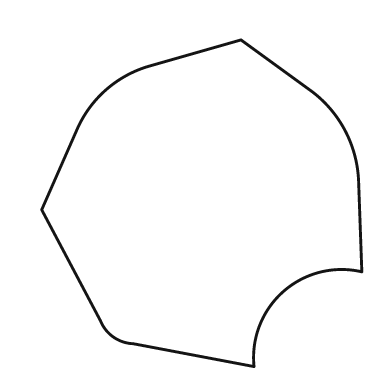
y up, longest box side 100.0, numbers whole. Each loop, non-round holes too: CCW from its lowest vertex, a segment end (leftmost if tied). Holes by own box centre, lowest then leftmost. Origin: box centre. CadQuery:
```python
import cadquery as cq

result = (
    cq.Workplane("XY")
    .moveTo(16.0, -50.0)
    .threePointArc((25.0, -27.0), (49.0, -21.0))
    .lineTo(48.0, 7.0)
    .threePointArc((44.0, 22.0), (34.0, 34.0))
    .lineTo(12.0, 50.0)
    .lineTo(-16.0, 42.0)
    .threePointArc((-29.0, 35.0), (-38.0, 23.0))
    .lineTo(-49.0, -2.0)
    .lineTo(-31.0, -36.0)
    .threePointArc((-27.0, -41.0), (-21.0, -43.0))
    .close()
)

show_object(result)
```